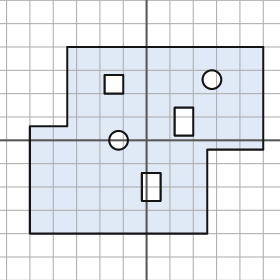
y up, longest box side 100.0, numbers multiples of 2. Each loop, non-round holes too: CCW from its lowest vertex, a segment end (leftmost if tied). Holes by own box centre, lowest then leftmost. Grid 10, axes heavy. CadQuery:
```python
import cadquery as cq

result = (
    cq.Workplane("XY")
    .moveTo(-50.0, -40.0)
    .lineTo(26.0, -40.0)
    .lineTo(26.0, -4.0)
    .lineTo(50.0, -4.0)
    .lineTo(50.0, 40.0)
    .lineTo(-34.0, 40.0)
    .lineTo(-34.0, 6.0)
    .lineTo(-50.0, 6.0)
    .close()
    .moveTo(-2.0, -26.0)
    .lineTo(6.0, -26.0)
    .lineTo(6.0, -14.0)
    .lineTo(-2.0, -14.0)
    .close()
    .moveTo(-12.0, 0.0)
    .circle(4.0)
    .moveTo(12.0, 2.0)
    .lineTo(20.0, 2.0)
    .lineTo(20.0, 14.0)
    .lineTo(12.0, 14.0)
    .close()
    .moveTo(-18.0, 20.0)
    .lineTo(-10.0, 20.0)
    .lineTo(-10.0, 28.0)
    .lineTo(-18.0, 28.0)
    .close()
    .moveTo(28.0, 26.0)
    .circle(4.0)
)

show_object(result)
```